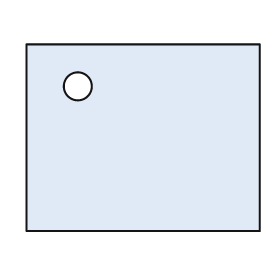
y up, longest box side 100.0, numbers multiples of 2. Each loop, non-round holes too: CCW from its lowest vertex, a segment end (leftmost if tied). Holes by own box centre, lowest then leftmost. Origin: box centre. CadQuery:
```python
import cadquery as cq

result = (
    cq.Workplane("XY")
    .moveTo(-50.0, -40.0)
    .lineTo(50.0, -40.0)
    .lineTo(50.0, 40.0)
    .lineTo(-50.0, 40.0)
    .close()
    .moveTo(-28.0, 22.0)
    .circle(6.0)
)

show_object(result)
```